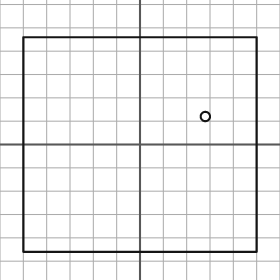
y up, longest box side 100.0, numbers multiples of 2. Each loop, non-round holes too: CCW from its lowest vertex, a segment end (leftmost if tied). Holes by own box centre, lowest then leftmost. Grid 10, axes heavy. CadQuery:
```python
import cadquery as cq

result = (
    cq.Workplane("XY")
    .moveTo(-50.0, -46.0)
    .lineTo(50.0, -46.0)
    .lineTo(50.0, 46.0)
    .lineTo(-50.0, 46.0)
    .close()
    .moveTo(28.0, 12.0)
    .circle(2.0)
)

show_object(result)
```